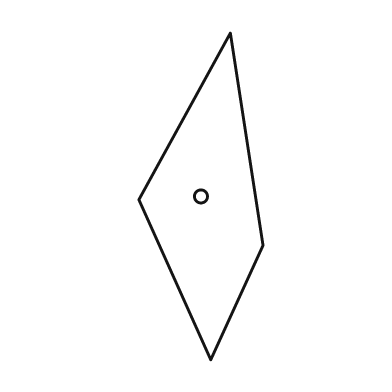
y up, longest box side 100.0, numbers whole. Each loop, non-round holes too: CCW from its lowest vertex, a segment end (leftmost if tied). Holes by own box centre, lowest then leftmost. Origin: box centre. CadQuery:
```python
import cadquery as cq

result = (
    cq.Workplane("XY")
    .moveTo(3.0, -50.0)
    .lineTo(19.0, -15.0)
    .lineTo(9.0, 50.0)
    .lineTo(-19.0, -1.0)
    .close()
    .moveTo(0.0, 0.0)
    .circle(2.0)
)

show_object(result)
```